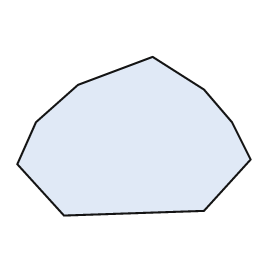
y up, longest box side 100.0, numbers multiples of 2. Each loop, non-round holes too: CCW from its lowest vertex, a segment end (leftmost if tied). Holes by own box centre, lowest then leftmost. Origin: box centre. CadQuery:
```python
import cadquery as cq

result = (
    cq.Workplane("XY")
    .moveTo(-30.0, -34.0)
    .lineTo(30.0, -32.0)
    .lineTo(50.0, -10.0)
    .lineTo(42.0, 6.0)
    .lineTo(30.0, 20.0)
    .lineTo(8.0, 34.0)
    .lineTo(-24.0, 22.0)
    .lineTo(-42.0, 6.0)
    .lineTo(-50.0, -12.0)
    .close()
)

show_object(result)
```